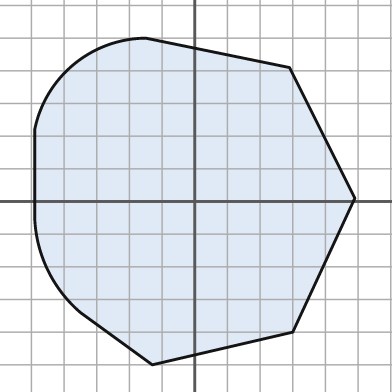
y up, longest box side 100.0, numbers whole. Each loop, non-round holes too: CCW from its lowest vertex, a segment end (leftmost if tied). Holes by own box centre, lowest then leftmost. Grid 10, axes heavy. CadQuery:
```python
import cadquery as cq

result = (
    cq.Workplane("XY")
    .moveTo(-13.0, -50.0)
    .lineTo(30.0, -40.0)
    .lineTo(49.0, 1.0)
    .lineTo(29.0, 41.0)
    .lineTo(-15.0, 50.0)
    .threePointArc((-37.0, 42.0), (-49.0, 22.0))
    .lineTo(-49.0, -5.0)
    .threePointArc((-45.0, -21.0), (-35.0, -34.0))
    .close()
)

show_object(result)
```